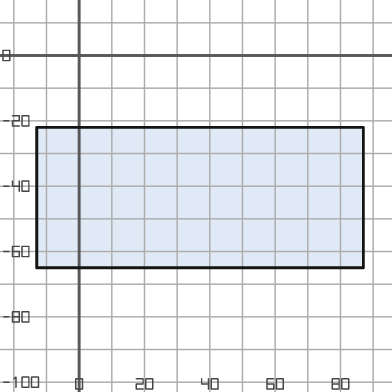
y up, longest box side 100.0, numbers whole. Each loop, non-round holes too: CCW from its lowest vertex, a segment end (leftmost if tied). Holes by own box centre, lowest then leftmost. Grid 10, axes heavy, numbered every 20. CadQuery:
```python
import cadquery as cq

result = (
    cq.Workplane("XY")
    .moveTo(-13.0, -65.0)
    .lineTo(87.0, -65.0)
    .lineTo(87.0, -22.0)
    .lineTo(-13.0, -22.0)
    .close()
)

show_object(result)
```